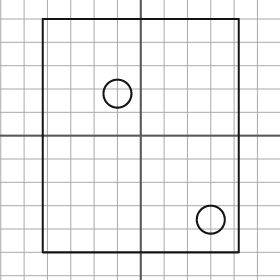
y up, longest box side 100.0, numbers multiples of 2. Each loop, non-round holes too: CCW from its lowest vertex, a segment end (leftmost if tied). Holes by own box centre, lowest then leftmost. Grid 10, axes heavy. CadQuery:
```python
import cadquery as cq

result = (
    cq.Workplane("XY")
    .moveTo(-42.0, -50.0)
    .lineTo(42.0, -50.0)
    .lineTo(42.0, 50.0)
    .lineTo(-42.0, 50.0)
    .close()
    .moveTo(30.0, -36.0)
    .circle(6.0)
    .moveTo(-10.0, 18.0)
    .circle(6.0)
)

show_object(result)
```